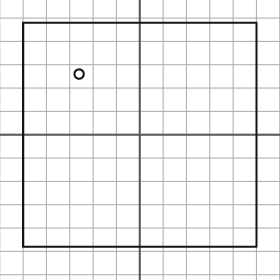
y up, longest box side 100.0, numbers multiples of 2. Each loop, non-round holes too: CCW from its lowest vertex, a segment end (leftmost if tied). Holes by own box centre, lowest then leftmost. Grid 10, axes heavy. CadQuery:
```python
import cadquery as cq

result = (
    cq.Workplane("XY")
    .moveTo(-50.0, -48.0)
    .lineTo(50.0, -48.0)
    .lineTo(50.0, 48.0)
    .lineTo(-50.0, 48.0)
    .close()
    .moveTo(-26.0, 26.0)
    .circle(2.0)
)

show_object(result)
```